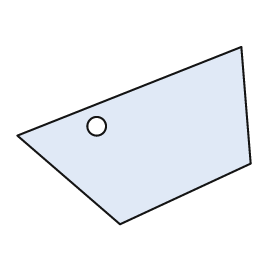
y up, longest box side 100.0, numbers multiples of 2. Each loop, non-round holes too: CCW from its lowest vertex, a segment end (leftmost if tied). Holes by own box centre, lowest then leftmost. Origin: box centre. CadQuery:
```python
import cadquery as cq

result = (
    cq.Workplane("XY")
    .moveTo(-6.0, -38.0)
    .lineTo(50.0, -12.0)
    .lineTo(46.0, 38.0)
    .lineTo(-50.0, 0.0)
    .close()
    .moveTo(-16.0, 4.0)
    .circle(4.0)
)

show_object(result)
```